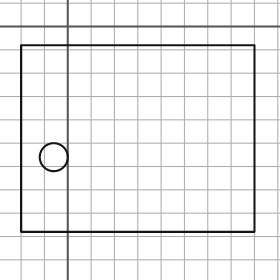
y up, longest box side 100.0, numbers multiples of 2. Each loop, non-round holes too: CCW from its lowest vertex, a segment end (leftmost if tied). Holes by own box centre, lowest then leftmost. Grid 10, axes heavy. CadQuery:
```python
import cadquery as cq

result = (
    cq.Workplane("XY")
    .moveTo(-20.0, -88.0)
    .lineTo(80.0, -88.0)
    .lineTo(80.0, -8.0)
    .lineTo(-20.0, -8.0)
    .close()
    .moveTo(-6.0, -56.0)
    .circle(6.0)
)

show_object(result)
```